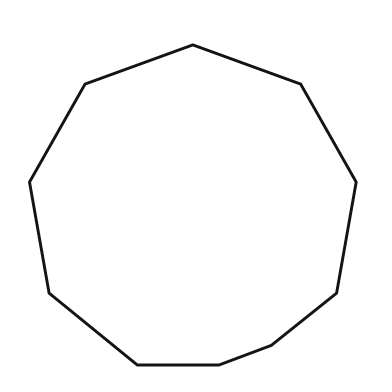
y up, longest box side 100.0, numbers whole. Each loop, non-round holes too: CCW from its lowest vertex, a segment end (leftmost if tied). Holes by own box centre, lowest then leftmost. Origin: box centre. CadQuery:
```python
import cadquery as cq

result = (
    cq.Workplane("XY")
    .moveTo(-17.0, -49.0)
    .lineTo(8.0, -49.0)
    .lineTo(24.0, -43.0)
    .lineTo(44.0, -27.0)
    .lineTo(50.0, 7.0)
    .lineTo(33.0, 37.0)
    .lineTo(0.0, 49.0)
    .lineTo(-33.0, 37.0)
    .lineTo(-50.0, 7.0)
    .lineTo(-44.0, -27.0)
    .close()
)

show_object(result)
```